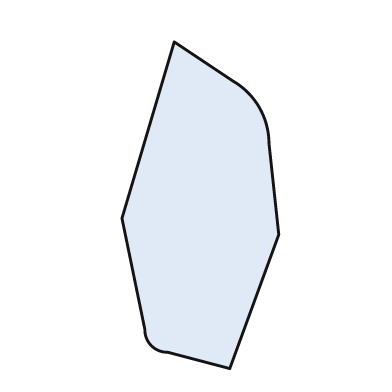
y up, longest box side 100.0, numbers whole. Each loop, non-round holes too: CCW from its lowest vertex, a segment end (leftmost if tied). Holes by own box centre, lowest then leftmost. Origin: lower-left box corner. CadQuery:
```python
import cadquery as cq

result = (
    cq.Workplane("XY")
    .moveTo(33.0, 0.0)
    .lineTo(48.0, 41.0)
    .lineTo(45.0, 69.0)
    .threePointArc((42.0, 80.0), (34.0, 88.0))
    .lineTo(16.0, 100.0)
    .lineTo(0.0, 46.0)
    .lineTo(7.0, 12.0)
    .threePointArc((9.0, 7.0), (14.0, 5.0))
    .close()
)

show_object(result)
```